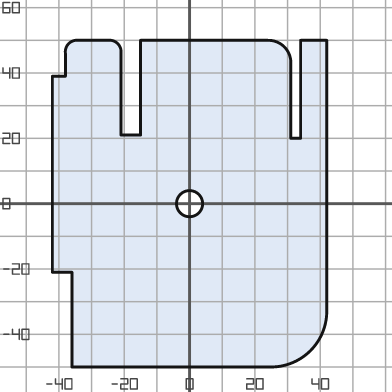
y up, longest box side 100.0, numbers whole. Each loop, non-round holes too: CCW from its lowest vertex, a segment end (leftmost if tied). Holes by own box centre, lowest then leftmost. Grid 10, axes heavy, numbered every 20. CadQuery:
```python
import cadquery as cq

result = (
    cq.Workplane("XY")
    .moveTo(-36.0, -50.0)
    .lineTo(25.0, -50.0)
    .threePointArc((37.0, -45.0), (42.0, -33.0))
    .lineTo(42.0, 50.0)
    .lineTo(34.0, 50.0)
    .lineTo(34.0, 20.0)
    .lineTo(31.0, 20.0)
    .lineTo(31.0, 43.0)
    .threePointArc((29.0, 48.0), (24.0, 50.0))
    .lineTo(-15.0, 50.0)
    .lineTo(-15.0, 21.0)
    .lineTo(-21.0, 21.0)
    .lineTo(-21.0, 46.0)
    .threePointArc((-22.0, 49.0), (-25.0, 50.0))
    .lineTo(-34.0, 50.0)
    .threePointArc((-37.0, 49.0), (-38.0, 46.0))
    .lineTo(-38.0, 39.0)
    .lineTo(-42.0, 39.0)
    .lineTo(-42.0, -21.0)
    .lineTo(-36.0, -21.0)
    .close()
    .moveTo(0.0, 0.0)
    .circle(4.0)
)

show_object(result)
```